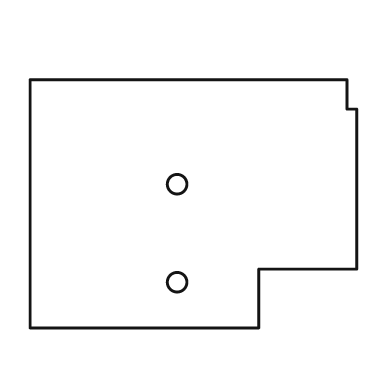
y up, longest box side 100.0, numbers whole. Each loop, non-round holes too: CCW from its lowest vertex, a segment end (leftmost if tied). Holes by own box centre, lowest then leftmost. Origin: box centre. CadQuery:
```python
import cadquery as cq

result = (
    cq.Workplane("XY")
    .moveTo(-50.0, -38.0)
    .lineTo(20.0, -38.0)
    .lineTo(20.0, -20.0)
    .lineTo(50.0, -20.0)
    .lineTo(50.0, 29.0)
    .lineTo(47.0, 29.0)
    .lineTo(47.0, 38.0)
    .lineTo(-50.0, 38.0)
    .close()
    .moveTo(-5.0, -24.0)
    .circle(3.0)
    .moveTo(-5.0, 6.0)
    .circle(3.0)
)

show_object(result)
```